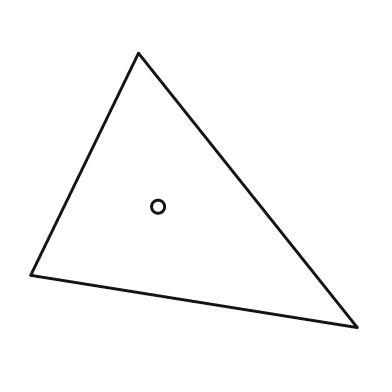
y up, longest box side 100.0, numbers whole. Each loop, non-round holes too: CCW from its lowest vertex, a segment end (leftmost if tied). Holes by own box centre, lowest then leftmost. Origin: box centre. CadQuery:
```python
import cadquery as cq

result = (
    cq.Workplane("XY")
    .moveTo(50.0, -42.0)
    .lineTo(-17.0, 42.0)
    .lineTo(-50.0, -26.0)
    .close()
    .moveTo(-11.0, -5.0)
    .circle(2.0)
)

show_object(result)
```